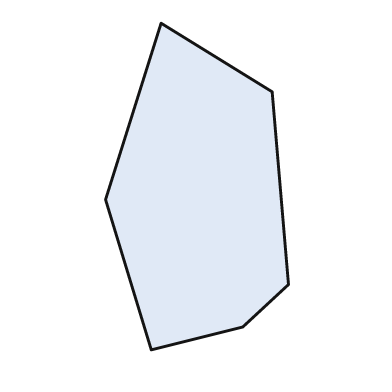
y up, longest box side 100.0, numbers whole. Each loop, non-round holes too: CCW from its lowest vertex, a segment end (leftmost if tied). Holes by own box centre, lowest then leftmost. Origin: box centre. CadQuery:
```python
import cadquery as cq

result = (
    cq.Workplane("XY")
    .moveTo(-14.0, -50.0)
    .lineTo(14.0, -43.0)
    .lineTo(28.0, -30.0)
    .lineTo(23.0, 29.0)
    .lineTo(-11.0, 50.0)
    .lineTo(-28.0, -4.0)
    .close()
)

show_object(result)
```